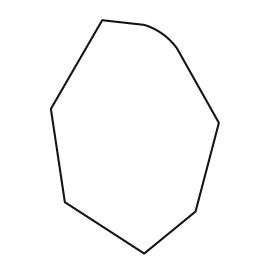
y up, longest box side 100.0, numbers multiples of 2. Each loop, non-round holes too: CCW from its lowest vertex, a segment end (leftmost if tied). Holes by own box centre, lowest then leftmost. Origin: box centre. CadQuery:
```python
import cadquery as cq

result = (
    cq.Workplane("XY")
    .moveTo(4.0, -50.0)
    .lineTo(26.0, -32.0)
    .lineTo(36.0, 6.0)
    .lineTo(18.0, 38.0)
    .threePointArc((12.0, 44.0), (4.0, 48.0))
    .lineTo(-14.0, 50.0)
    .lineTo(-36.0, 12.0)
    .lineTo(-30.0, -28.0)
    .close()
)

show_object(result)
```